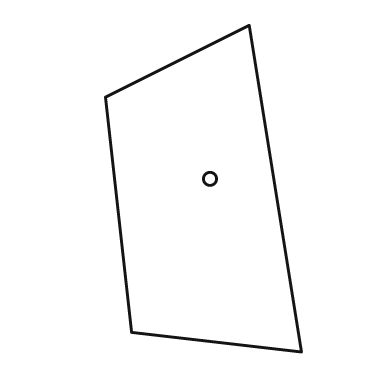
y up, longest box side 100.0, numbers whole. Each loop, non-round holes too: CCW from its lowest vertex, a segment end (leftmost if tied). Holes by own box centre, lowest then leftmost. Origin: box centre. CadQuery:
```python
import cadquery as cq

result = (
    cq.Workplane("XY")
    .moveTo(30.0, -50.0)
    .lineTo(14.0, 50.0)
    .lineTo(-30.0, 28.0)
    .lineTo(-22.0, -44.0)
    .close()
    .moveTo(2.0, 3.0)
    .circle(2.0)
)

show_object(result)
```